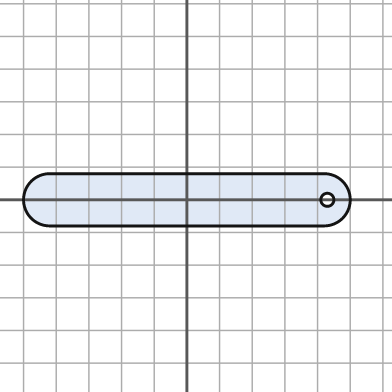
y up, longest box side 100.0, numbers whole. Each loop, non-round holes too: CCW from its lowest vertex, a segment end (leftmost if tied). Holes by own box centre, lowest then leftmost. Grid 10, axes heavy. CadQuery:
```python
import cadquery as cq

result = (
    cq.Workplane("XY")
    .moveTo(-42.0, -8.0)
    .lineTo(42.0, -8.0)
    .threePointArc((50.0, 0.0), (42.0, 8.0))
    .lineTo(-42.0, 8.0)
    .threePointArc((-50.0, 0.0), (-42.0, -8.0))
    .close()
    .moveTo(43.0, 0.0)
    .circle(2.0)
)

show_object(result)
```